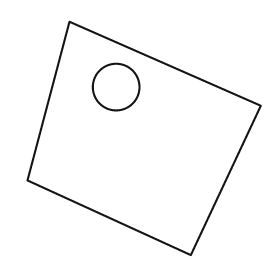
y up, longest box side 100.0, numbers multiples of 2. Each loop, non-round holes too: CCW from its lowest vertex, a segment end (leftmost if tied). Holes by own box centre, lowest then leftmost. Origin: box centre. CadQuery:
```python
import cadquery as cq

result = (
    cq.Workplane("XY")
    .moveTo(20.0, -50.0)
    .lineTo(50.0, 14.0)
    .lineTo(-32.0, 50.0)
    .lineTo(-50.0, -18.0)
    .close()
    .moveTo(-12.0, 22.0)
    .circle(10.0)
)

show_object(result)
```